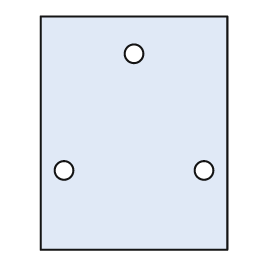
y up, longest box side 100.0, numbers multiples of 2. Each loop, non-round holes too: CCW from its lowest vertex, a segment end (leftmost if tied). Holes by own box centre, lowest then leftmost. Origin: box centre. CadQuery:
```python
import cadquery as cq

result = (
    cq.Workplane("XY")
    .moveTo(-40.0, -50.0)
    .lineTo(40.0, -50.0)
    .lineTo(40.0, 50.0)
    .lineTo(-40.0, 50.0)
    .close()
    .moveTo(-30.0, -16.0)
    .circle(4.0)
    .moveTo(30.0, -16.0)
    .circle(4.0)
    .moveTo(0.0, 34.0)
    .circle(4.0)
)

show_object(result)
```